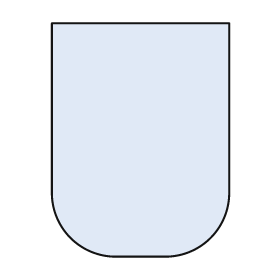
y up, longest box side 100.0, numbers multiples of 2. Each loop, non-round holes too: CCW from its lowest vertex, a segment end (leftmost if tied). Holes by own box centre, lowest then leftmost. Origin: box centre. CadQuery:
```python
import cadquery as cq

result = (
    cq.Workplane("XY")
    .moveTo(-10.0, -50.0)
    .lineTo(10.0, -50.0)
    .threePointArc((30.0, -42.0), (38.0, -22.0))
    .lineTo(38.0, 50.0)
    .lineTo(-38.0, 50.0)
    .lineTo(-38.0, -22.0)
    .threePointArc((-30.0, -42.0), (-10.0, -50.0))
    .close()
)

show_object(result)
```